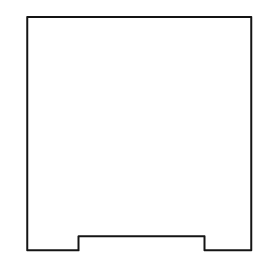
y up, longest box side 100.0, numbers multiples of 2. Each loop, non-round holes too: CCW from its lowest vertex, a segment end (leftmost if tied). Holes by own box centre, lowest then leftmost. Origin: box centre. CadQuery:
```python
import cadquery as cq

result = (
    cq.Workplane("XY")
    .moveTo(-48.0, -50.0)
    .lineTo(-26.0, -50.0)
    .lineTo(-26.0, -44.0)
    .lineTo(28.0, -44.0)
    .lineTo(28.0, -50.0)
    .lineTo(48.0, -50.0)
    .lineTo(48.0, 50.0)
    .lineTo(-48.0, 50.0)
    .close()
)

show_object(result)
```